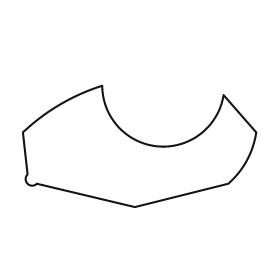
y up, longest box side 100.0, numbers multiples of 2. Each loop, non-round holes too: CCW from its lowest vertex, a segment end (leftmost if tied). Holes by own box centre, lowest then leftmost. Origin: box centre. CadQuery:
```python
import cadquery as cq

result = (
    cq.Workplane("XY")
    .moveTo(-2.0, -26.0)
    .lineTo(38.0, -16.0)
    .threePointArc((46.0, -6.0), (50.0, 6.0))
    .lineTo(36.0, 22.0)
    .threePointArc((8.0, 0.0), (-16.0, 26.0))
    .threePointArc((-34.0, 18.0), (-50.0, 6.0))
    .lineTo(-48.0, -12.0)
    .threePointArc((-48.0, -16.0), (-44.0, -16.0))
    .close()
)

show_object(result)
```